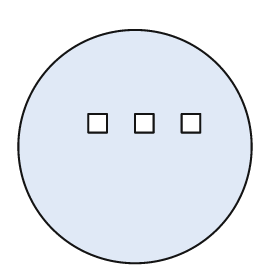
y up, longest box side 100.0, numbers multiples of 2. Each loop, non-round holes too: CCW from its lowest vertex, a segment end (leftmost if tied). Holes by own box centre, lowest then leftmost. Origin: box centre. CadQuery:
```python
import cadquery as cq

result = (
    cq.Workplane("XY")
    .moveTo(0.0, 0.0)
    .circle(50.0)
    .moveTo(-20.0, 6.0)
    .lineTo(-12.0, 6.0)
    .lineTo(-12.0, 14.0)
    .lineTo(-20.0, 14.0)
    .close()
    .moveTo(0.0, 6.0)
    .lineTo(8.0, 6.0)
    .lineTo(8.0, 14.0)
    .lineTo(0.0, 14.0)
    .close()
    .moveTo(20.0, 6.0)
    .lineTo(28.0, 6.0)
    .lineTo(28.0, 14.0)
    .lineTo(20.0, 14.0)
    .close()
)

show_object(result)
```